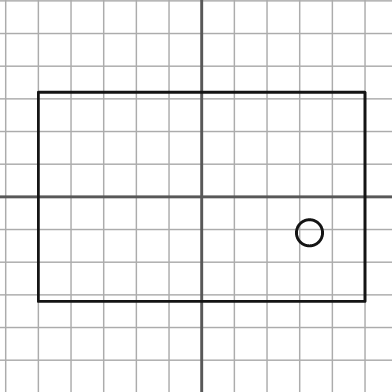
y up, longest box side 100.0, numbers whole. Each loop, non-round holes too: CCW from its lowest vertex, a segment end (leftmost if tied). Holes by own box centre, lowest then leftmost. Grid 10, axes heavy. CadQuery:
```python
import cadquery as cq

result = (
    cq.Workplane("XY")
    .moveTo(-50.0, -32.0)
    .lineTo(50.0, -32.0)
    .lineTo(50.0, 32.0)
    .lineTo(-50.0, 32.0)
    .close()
    .moveTo(33.0, -11.0)
    .circle(4.0)
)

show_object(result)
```